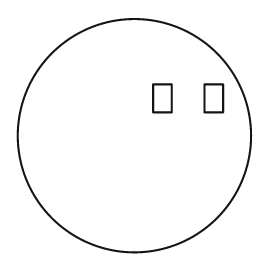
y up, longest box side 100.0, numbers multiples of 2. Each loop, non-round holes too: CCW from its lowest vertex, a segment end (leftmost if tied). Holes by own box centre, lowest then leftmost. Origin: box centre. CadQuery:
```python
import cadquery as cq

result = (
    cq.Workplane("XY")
    .moveTo(0.0, 0.0)
    .circle(50.0)
    .moveTo(8.0, 10.0)
    .lineTo(16.0, 10.0)
    .lineTo(16.0, 22.0)
    .lineTo(8.0, 22.0)
    .close()
    .moveTo(30.0, 10.0)
    .lineTo(38.0, 10.0)
    .lineTo(38.0, 22.0)
    .lineTo(30.0, 22.0)
    .close()
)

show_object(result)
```